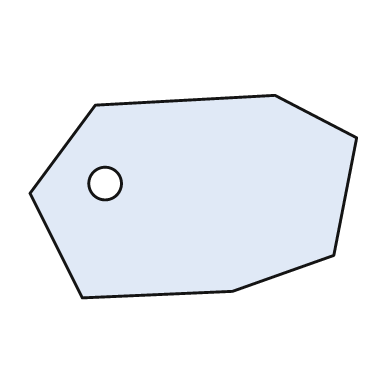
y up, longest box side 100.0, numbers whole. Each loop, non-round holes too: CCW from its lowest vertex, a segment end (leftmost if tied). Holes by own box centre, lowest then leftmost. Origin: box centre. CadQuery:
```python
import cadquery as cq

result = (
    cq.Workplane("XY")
    .moveTo(-34.0, -31.0)
    .lineTo(12.0, -29.0)
    .lineTo(43.0, -18.0)
    .lineTo(50.0, 18.0)
    .lineTo(25.0, 31.0)
    .lineTo(-30.0, 28.0)
    .lineTo(-50.0, 1.0)
    .close()
    .moveTo(-27.0, 4.0)
    .circle(5.0)
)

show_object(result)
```